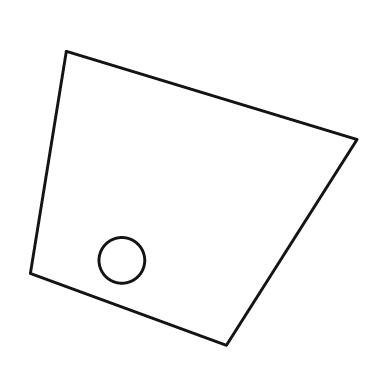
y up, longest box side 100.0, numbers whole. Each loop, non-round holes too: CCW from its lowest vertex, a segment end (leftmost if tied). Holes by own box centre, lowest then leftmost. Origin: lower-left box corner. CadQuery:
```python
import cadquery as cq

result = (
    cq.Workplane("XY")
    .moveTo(60.0, 0.0)
    .lineTo(100.0, 63.0)
    .lineTo(11.0, 90.0)
    .lineTo(0.0, 22.0)
    .close()
    .moveTo(28.0, 26.0)
    .circle(7.0)
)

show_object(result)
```